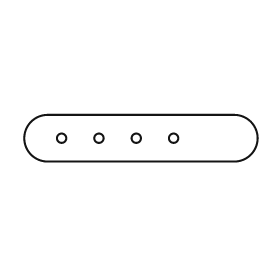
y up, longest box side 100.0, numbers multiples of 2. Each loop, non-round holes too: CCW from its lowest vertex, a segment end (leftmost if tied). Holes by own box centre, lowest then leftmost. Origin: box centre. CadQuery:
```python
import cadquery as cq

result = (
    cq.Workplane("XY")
    .moveTo(-40.0, -10.0)
    .lineTo(40.0, -10.0)
    .threePointArc((50.0, 0.0), (40.0, 10.0))
    .lineTo(-40.0, 10.0)
    .threePointArc((-50.0, 0.0), (-40.0, -10.0))
    .close()
    .moveTo(-34.0, 0.0)
    .circle(2.0)
    .moveTo(-18.0, 0.0)
    .circle(2.0)
    .moveTo(-2.0, 0.0)
    .circle(2.0)
    .moveTo(14.0, 0.0)
    .circle(2.0)
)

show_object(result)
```